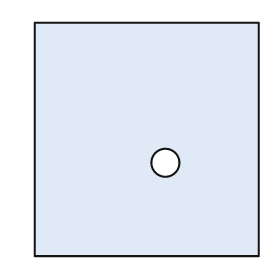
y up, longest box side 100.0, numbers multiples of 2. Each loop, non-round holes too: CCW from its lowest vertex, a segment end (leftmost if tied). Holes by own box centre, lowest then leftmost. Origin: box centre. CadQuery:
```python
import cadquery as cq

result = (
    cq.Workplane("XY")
    .moveTo(-48.0, -50.0)
    .lineTo(48.0, -50.0)
    .lineTo(48.0, 50.0)
    .lineTo(-48.0, 50.0)
    .close()
    .moveTo(8.0, -10.0)
    .circle(6.0)
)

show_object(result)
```